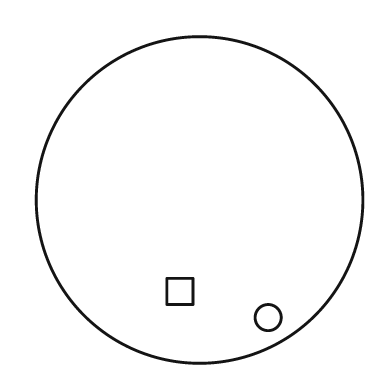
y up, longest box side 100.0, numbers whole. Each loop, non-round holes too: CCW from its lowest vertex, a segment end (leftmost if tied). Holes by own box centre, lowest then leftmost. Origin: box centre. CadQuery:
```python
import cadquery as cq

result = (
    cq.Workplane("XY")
    .moveTo(0.0, 0.0)
    .circle(50.0)
    .moveTo(21.0, -36.0)
    .circle(4.0)
    .moveTo(-10.0, -32.0)
    .lineTo(-2.0, -32.0)
    .lineTo(-2.0, -24.0)
    .lineTo(-10.0, -24.0)
    .close()
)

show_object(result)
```